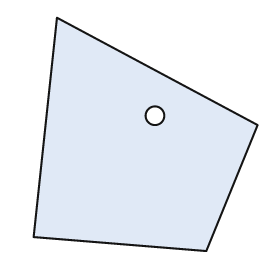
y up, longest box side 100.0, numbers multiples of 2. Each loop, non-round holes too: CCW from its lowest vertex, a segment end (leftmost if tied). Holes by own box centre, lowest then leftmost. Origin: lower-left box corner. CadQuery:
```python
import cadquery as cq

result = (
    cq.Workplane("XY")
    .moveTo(74.0, 0.0)
    .lineTo(96.0, 54.0)
    .lineTo(10.0, 100.0)
    .lineTo(0.0, 6.0)
    .close()
    .moveTo(52.0, 58.0)
    .circle(4.0)
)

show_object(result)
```